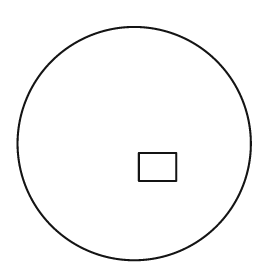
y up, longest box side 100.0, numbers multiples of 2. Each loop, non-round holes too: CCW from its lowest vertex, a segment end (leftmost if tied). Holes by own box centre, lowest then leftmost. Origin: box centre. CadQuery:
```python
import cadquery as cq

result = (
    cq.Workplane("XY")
    .moveTo(0.0, 0.0)
    .circle(50.0)
    .moveTo(2.0, -16.0)
    .lineTo(18.0, -16.0)
    .lineTo(18.0, -4.0)
    .lineTo(2.0, -4.0)
    .close()
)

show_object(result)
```